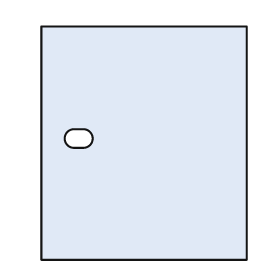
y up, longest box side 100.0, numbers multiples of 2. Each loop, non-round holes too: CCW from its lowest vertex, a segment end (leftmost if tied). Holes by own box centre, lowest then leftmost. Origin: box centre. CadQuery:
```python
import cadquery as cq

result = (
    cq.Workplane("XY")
    .moveTo(-44.0, -50.0)
    .lineTo(44.0, -50.0)
    .lineTo(44.0, 50.0)
    .lineTo(-44.0, 50.0)
    .close()
    .moveTo(-30.0, -2.0)
    .lineTo(-26.0, -2.0)
    .threePointArc((-22.0, 2.0), (-26.0, 6.0))
    .lineTo(-30.0, 6.0)
    .threePointArc((-34.0, 2.0), (-30.0, -2.0))
    .close()
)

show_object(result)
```